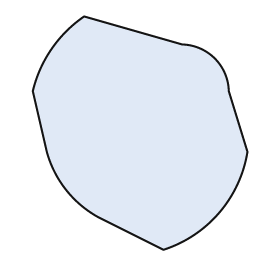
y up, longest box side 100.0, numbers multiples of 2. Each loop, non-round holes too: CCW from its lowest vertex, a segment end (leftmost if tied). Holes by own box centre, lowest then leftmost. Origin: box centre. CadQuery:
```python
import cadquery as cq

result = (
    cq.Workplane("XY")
    .moveTo(10.0, -50.0)
    .threePointArc((34.0, -34.0), (46.0, -8.0))
    .lineTo(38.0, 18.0)
    .threePointArc((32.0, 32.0), (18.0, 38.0))
    .lineTo(-24.0, 50.0)
    .threePointArc((-38.0, 36.0), (-46.0, 18.0))
    .lineTo(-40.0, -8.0)
    .threePointArc((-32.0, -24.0), (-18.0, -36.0))
    .close()
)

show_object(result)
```